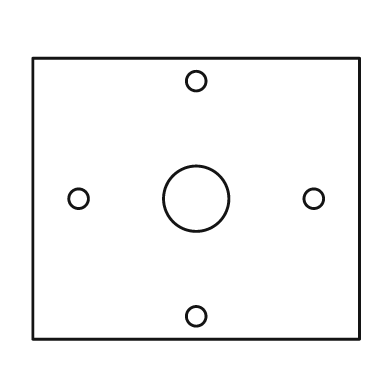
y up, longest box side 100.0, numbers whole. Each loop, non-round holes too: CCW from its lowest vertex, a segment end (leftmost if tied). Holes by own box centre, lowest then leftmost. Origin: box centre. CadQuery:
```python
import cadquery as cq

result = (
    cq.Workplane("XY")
    .moveTo(-50.0, -43.0)
    .lineTo(50.0, -43.0)
    .lineTo(50.0, 43.0)
    .lineTo(-50.0, 43.0)
    .close()
    .moveTo(0.0, -36.0)
    .circle(3.0)
    .moveTo(-36.0, 0.0)
    .circle(3.0)
    .moveTo(0.0, 0.0)
    .circle(10.0)
    .moveTo(36.0, 0.0)
    .circle(3.0)
    .moveTo(0.0, 36.0)
    .circle(3.0)
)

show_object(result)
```